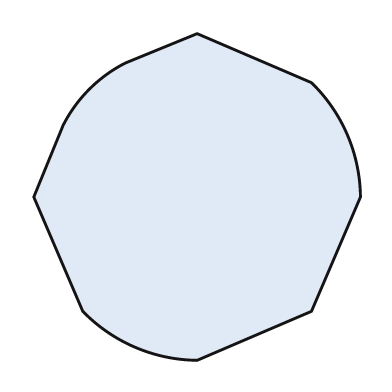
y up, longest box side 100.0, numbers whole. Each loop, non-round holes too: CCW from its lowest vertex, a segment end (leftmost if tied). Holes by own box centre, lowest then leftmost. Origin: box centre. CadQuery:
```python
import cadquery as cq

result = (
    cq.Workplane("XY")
    .moveTo(0.0, -50.0)
    .lineTo(35.0, -35.0)
    .lineTo(50.0, 0.0)
    .threePointArc((46.0, 19.0), (35.0, 35.0))
    .lineTo(0.0, 50.0)
    .lineTo(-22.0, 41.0)
    .threePointArc((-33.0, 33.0), (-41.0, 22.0))
    .lineTo(-50.0, 0.0)
    .lineTo(-35.0, -35.0)
    .threePointArc((-19.0, -46.0), (0.0, -50.0))
    .close()
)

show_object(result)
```